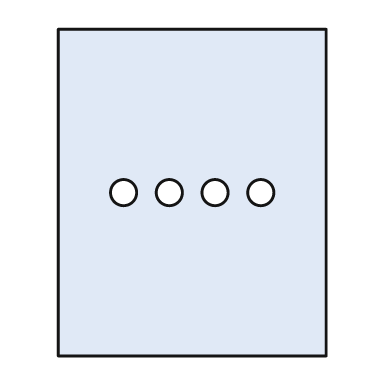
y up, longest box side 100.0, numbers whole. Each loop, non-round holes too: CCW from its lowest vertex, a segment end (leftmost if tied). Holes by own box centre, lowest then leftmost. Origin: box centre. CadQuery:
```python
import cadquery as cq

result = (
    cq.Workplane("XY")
    .moveTo(-41.0, -50.0)
    .lineTo(41.0, -50.0)
    .lineTo(41.0, 50.0)
    .lineTo(-41.0, 50.0)
    .close()
    .moveTo(-21.0, 0.0)
    .circle(4.0)
    .moveTo(-7.0, 0.0)
    .circle(4.0)
    .moveTo(7.0, 0.0)
    .circle(4.0)
    .moveTo(21.0, 0.0)
    .circle(4.0)
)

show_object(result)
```